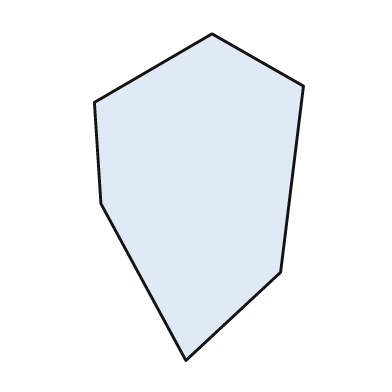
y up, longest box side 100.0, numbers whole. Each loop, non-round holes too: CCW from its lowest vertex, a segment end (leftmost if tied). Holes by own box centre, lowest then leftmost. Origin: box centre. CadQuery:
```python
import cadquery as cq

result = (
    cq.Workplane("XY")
    .moveTo(-4.0, -50.0)
    .lineTo(25.0, -23.0)
    .lineTo(32.0, 34.0)
    .lineTo(4.0, 50.0)
    .lineTo(-32.0, 29.0)
    .lineTo(-30.0, -2.0)
    .close()
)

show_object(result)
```